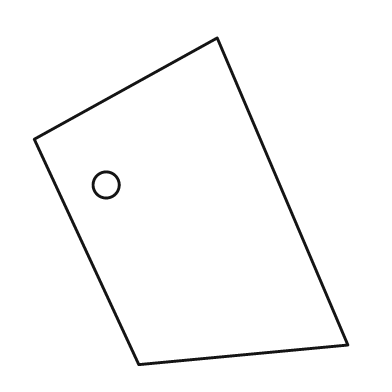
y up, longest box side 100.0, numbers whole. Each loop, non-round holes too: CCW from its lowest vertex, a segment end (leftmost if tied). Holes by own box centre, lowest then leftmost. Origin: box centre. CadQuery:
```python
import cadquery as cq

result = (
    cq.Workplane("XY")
    .moveTo(-16.0, -50.0)
    .lineTo(48.0, -44.0)
    .lineTo(8.0, 50.0)
    .lineTo(-48.0, 19.0)
    .close()
    .moveTo(-26.0, 5.0)
    .circle(4.0)
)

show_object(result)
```